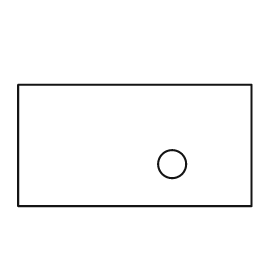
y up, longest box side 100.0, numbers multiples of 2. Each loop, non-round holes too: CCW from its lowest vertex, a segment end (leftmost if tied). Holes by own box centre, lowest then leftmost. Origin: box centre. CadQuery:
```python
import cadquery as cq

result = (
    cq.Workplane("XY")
    .moveTo(-50.0, -26.0)
    .lineTo(50.0, -26.0)
    .lineTo(50.0, 26.0)
    .lineTo(-50.0, 26.0)
    .close()
    .moveTo(16.0, -8.0)
    .circle(6.0)
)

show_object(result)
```